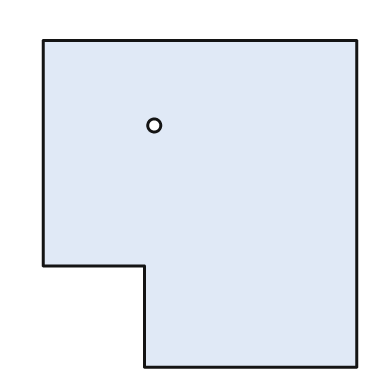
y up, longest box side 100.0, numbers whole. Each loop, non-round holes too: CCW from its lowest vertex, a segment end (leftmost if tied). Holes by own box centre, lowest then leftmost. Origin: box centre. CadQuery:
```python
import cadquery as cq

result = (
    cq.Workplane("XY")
    .moveTo(-17.0, -50.0)
    .lineTo(48.0, -50.0)
    .lineTo(48.0, 50.0)
    .lineTo(-48.0, 50.0)
    .lineTo(-48.0, -19.0)
    .lineTo(-17.0, -19.0)
    .close()
    .moveTo(-14.0, 24.0)
    .circle(2.0)
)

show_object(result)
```